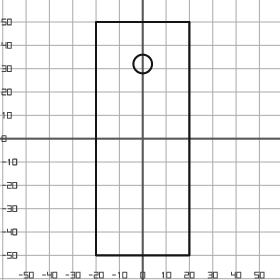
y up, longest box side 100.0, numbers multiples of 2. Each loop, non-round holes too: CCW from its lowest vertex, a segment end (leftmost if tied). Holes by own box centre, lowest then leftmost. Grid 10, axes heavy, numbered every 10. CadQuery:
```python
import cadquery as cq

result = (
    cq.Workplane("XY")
    .moveTo(-20.0, -50.0)
    .lineTo(20.0, -50.0)
    .lineTo(20.0, 50.0)
    .lineTo(-20.0, 50.0)
    .close()
    .moveTo(0.0, 32.0)
    .circle(4.0)
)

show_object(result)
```